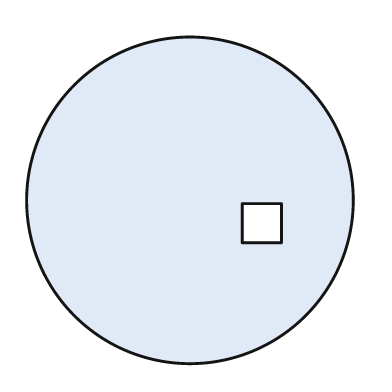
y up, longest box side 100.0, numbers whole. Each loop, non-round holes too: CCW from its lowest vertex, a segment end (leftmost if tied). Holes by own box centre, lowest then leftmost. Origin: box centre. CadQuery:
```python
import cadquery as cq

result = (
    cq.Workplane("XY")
    .moveTo(0.0, 0.0)
    .circle(50.0)
    .moveTo(16.0, -13.0)
    .lineTo(28.0, -13.0)
    .lineTo(28.0, -1.0)
    .lineTo(16.0, -1.0)
    .close()
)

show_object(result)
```